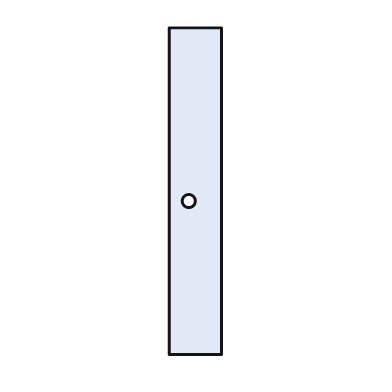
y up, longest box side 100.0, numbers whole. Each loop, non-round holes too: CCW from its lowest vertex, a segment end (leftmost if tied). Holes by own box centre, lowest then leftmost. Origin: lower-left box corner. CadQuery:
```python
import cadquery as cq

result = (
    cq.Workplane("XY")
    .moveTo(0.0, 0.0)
    .lineTo(16.0, 0.0)
    .lineTo(16.0, 100.0)
    .lineTo(0.0, 100.0)
    .close()
    .moveTo(6.0, 47.0)
    .circle(2.0)
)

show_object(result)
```